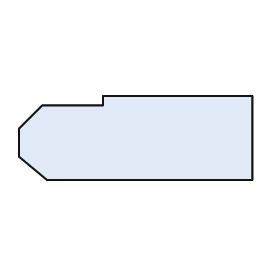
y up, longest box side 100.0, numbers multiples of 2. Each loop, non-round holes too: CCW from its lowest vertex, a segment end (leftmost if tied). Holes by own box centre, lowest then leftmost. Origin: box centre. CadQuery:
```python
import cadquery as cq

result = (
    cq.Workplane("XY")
    .moveTo(-38.0, -18.0)
    .lineTo(50.0, -18.0)
    .lineTo(50.0, 18.0)
    .lineTo(-14.0, 18.0)
    .lineTo(-14.0, 14.0)
    .lineTo(-40.0, 14.0)
    .lineTo(-50.0, 4.0)
    .lineTo(-50.0, -8.0)
    .close()
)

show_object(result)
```